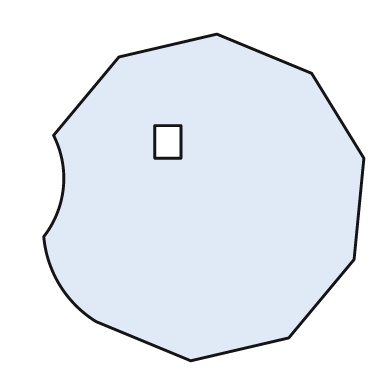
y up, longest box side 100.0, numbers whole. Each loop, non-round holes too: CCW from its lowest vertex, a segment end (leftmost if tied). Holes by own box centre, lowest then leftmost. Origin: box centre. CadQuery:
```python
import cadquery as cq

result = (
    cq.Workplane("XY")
    .moveTo(-4.0, -50.0)
    .lineTo(26.0, -43.0)
    .lineTo(46.0, -19.0)
    .lineTo(49.0, 12.0)
    .lineTo(33.0, 38.0)
    .lineTo(4.0, 50.0)
    .lineTo(-26.0, 43.0)
    .lineTo(-46.0, 19.0)
    .threePointArc((-43.0, 3.0), (-49.0, -12.0))
    .threePointArc((-44.0, -27.0), (-33.0, -38.0))
    .close()
    .moveTo(-15.0, 12.0)
    .lineTo(-7.0, 12.0)
    .lineTo(-7.0, 22.0)
    .lineTo(-15.0, 22.0)
    .close()
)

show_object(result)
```